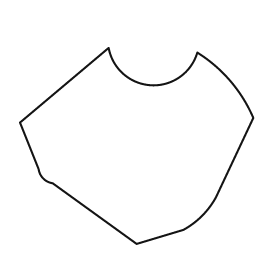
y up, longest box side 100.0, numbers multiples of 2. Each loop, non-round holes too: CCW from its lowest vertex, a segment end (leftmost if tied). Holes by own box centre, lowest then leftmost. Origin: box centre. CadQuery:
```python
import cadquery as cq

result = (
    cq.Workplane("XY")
    .moveTo(0.0, -42.0)
    .lineTo(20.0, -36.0)
    .threePointArc((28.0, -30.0), (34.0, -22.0))
    .lineTo(50.0, 12.0)
    .threePointArc((40.0, 28.0), (26.0, 40.0))
    .threePointArc((6.0, 26.0), (-12.0, 42.0))
    .lineTo(-50.0, 10.0)
    .lineTo(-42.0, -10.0)
    .threePointArc((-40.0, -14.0), (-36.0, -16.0))
    .close()
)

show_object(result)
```